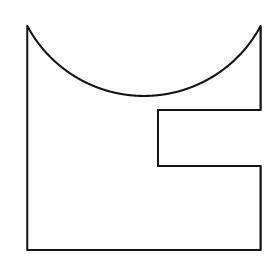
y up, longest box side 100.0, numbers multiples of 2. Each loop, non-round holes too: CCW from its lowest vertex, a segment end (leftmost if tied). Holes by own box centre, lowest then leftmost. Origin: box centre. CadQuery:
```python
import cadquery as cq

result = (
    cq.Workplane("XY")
    .moveTo(-50.0, -48.0)
    .lineTo(50.0, -48.0)
    .lineTo(50.0, -12.0)
    .lineTo(6.0, -12.0)
    .lineTo(6.0, 12.0)
    .lineTo(50.0, 12.0)
    .lineTo(50.0, 48.0)
    .threePointArc((0.0, 18.0), (-50.0, 48.0))
    .close()
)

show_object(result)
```